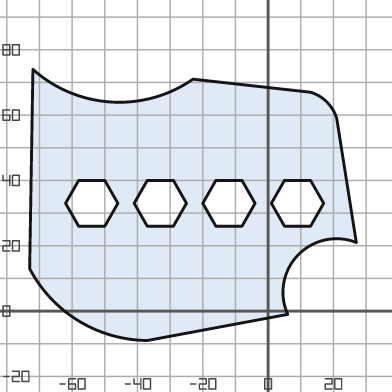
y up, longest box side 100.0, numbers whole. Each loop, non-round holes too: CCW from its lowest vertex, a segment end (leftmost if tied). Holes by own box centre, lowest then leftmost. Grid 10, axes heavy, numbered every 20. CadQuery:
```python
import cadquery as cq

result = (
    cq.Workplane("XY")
    .moveTo(-37.0, -9.0)
    .lineTo(6.0, -1.0)
    .threePointArc((9.0, 17.0), (27.0, 21.0))
    .lineTo(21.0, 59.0)
    .threePointArc((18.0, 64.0), (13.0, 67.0))
    .lineTo(-23.0, 71.0)
    .threePointArc((-48.0, 64.0), (-72.0, 74.0))
    .lineTo(-73.0, 13.0)
    .threePointArc((-58.0, -3.0), (-37.0, -9.0))
    .close()
    .moveTo(-58.0, 26.0)
    .lineTo(-50.0, 26.0)
    .lineTo(-46.0, 33.0)
    .lineTo(-50.0, 40.0)
    .lineTo(-58.0, 40.0)
    .lineTo(-62.0, 33.0)
    .close()
    .moveTo(-37.0, 26.0)
    .lineTo(-29.0, 26.0)
    .lineTo(-25.0, 33.0)
    .lineTo(-29.0, 40.0)
    .lineTo(-37.0, 40.0)
    .lineTo(-41.0, 33.0)
    .close()
    .moveTo(-16.0, 26.0)
    .lineTo(-8.0, 26.0)
    .lineTo(-4.0, 33.0)
    .lineTo(-8.0, 40.0)
    .lineTo(-16.0, 40.0)
    .lineTo(-20.0, 33.0)
    .close()
    .moveTo(5.0, 26.0)
    .lineTo(13.0, 26.0)
    .lineTo(17.0, 33.0)
    .lineTo(13.0, 40.0)
    .lineTo(5.0, 40.0)
    .lineTo(1.0, 33.0)
    .close()
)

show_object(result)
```